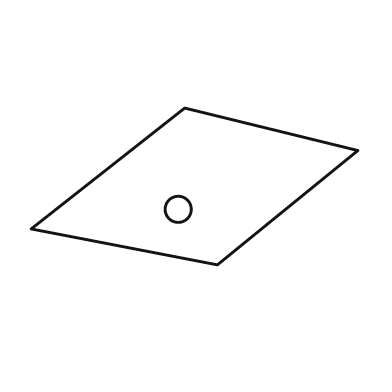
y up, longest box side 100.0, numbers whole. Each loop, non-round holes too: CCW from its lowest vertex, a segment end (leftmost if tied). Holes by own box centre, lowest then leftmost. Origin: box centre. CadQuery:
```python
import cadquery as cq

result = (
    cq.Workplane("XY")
    .moveTo(7.0, -24.0)
    .lineTo(50.0, 11.0)
    .lineTo(-3.0, 24.0)
    .lineTo(-50.0, -13.0)
    .close()
    .moveTo(-5.0, -7.0)
    .circle(4.0)
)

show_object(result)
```